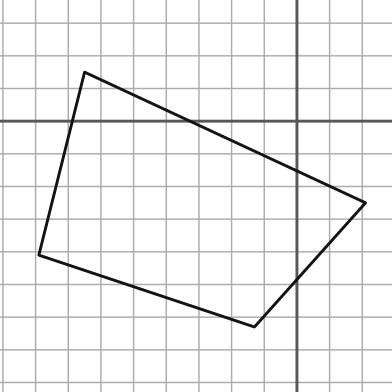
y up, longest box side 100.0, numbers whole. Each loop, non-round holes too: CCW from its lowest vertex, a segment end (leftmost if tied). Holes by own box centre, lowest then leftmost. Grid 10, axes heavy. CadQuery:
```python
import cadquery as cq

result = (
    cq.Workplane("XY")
    .moveTo(-13.0, -63.0)
    .lineTo(21.0, -25.0)
    .lineTo(-65.0, 15.0)
    .lineTo(-79.0, -41.0)
    .close()
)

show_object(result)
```